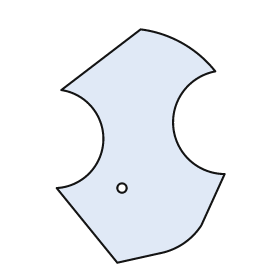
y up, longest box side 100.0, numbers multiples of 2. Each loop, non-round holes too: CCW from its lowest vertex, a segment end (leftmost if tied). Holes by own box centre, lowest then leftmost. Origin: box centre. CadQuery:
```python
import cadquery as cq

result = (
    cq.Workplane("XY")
    .moveTo(-10.0, -50.0)
    .lineTo(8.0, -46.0)
    .threePointArc((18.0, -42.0), (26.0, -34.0))
    .lineTo(36.0, -12.0)
    .threePointArc((14.0, 8.0), (32.0, 32.0))
    .threePointArc((18.0, 44.0), (0.0, 50.0))
    .lineTo(-34.0, 24.0)
    .threePointArc((-16.0, 2.0), (-36.0, -18.0))
    .close()
    .moveTo(-8.0, -18.0)
    .circle(2.0)
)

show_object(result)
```